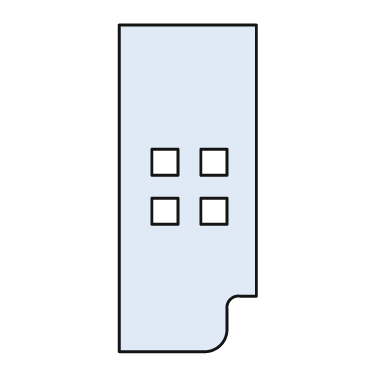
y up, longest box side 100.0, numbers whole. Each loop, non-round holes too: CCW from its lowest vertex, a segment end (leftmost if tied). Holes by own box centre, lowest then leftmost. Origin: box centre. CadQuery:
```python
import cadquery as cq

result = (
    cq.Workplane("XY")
    .moveTo(-21.0, -50.0)
    .lineTo(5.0, -50.0)
    .threePointArc((10.0, -48.0), (12.0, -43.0))
    .lineTo(12.0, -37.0)
    .threePointArc((13.0, -34.0), (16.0, -33.0))
    .lineTo(21.0, -33.0)
    .lineTo(21.0, 50.0)
    .lineTo(-21.0, 50.0)
    .close()
    .moveTo(-11.0, -11.0)
    .lineTo(-3.0, -11.0)
    .lineTo(-3.0, -3.0)
    .lineTo(-11.0, -3.0)
    .close()
    .moveTo(4.0, -11.0)
    .lineTo(12.0, -11.0)
    .lineTo(12.0, -3.0)
    .lineTo(4.0, -3.0)
    .close()
    .moveTo(-11.0, 4.0)
    .lineTo(-3.0, 4.0)
    .lineTo(-3.0, 12.0)
    .lineTo(-11.0, 12.0)
    .close()
    .moveTo(4.0, 4.0)
    .lineTo(12.0, 4.0)
    .lineTo(12.0, 12.0)
    .lineTo(4.0, 12.0)
    .close()
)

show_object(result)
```